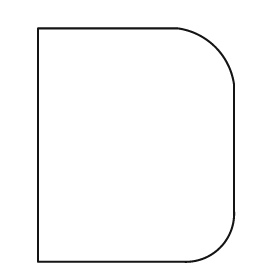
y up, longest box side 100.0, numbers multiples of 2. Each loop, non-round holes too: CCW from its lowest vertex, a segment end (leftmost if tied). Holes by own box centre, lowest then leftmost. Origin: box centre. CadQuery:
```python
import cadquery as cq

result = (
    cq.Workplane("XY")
    .moveTo(-42.0, -50.0)
    .lineTo(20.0, -50.0)
    .threePointArc((36.0, -44.0), (42.0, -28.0))
    .lineTo(42.0, 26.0)
    .threePointArc((34.0, 42.0), (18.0, 50.0))
    .lineTo(-42.0, 50.0)
    .close()
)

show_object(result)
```